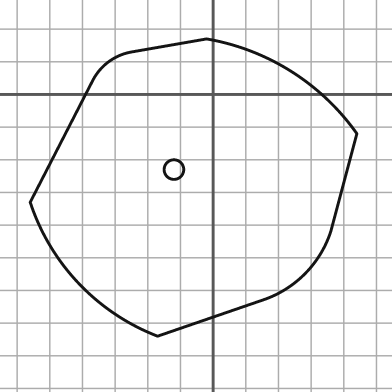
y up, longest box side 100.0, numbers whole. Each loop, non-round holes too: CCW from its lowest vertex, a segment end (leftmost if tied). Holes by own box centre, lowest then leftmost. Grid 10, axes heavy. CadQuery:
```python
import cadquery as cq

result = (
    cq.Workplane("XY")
    .moveTo(-17.0, -74.0)
    .lineTo(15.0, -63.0)
    .threePointArc((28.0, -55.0), (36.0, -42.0))
    .lineTo(44.0, -12.0)
    .threePointArc((24.0, 7.0), (-2.0, 17.0))
    .lineTo(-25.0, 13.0)
    .threePointArc((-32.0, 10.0), (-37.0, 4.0))
    .lineTo(-56.0, -33.0)
    .threePointArc((-41.0, -58.0), (-17.0, -74.0))
    .close()
    .moveTo(-12.0, -23.0)
    .circle(3.0)
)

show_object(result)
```